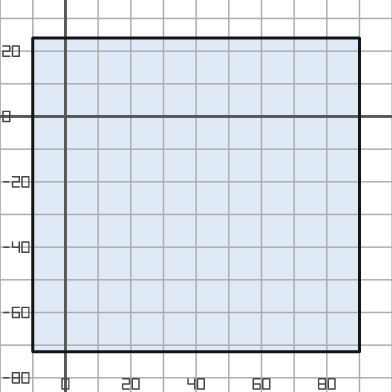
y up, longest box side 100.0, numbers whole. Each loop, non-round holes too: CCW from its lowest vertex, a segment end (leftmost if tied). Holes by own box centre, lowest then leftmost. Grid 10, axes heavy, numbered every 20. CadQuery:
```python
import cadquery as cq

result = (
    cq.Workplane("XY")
    .moveTo(-10.0, -72.0)
    .lineTo(90.0, -72.0)
    .lineTo(90.0, 24.0)
    .lineTo(-10.0, 24.0)
    .close()
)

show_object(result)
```